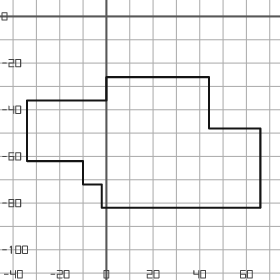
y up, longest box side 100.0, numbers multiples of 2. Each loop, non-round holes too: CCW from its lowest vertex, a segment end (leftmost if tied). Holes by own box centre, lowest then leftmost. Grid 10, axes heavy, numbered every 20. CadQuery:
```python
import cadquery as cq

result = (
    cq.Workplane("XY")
    .moveTo(-2.0, -82.0)
    .lineTo(66.0, -82.0)
    .lineTo(66.0, -48.0)
    .lineTo(44.0, -48.0)
    .lineTo(44.0, -26.0)
    .lineTo(0.0, -26.0)
    .lineTo(0.0, -36.0)
    .lineTo(-34.0, -36.0)
    .lineTo(-34.0, -62.0)
    .lineTo(-10.0, -62.0)
    .lineTo(-10.0, -72.0)
    .lineTo(-2.0, -72.0)
    .close()
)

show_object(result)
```